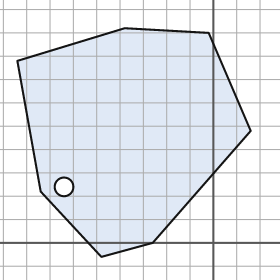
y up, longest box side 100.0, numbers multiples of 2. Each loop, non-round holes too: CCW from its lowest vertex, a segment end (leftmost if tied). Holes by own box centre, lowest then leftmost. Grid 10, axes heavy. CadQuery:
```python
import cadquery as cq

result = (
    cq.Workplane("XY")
    .moveTo(-48.0, -6.0)
    .lineTo(-26.0, 0.0)
    .lineTo(16.0, 48.0)
    .lineTo(-2.0, 90.0)
    .lineTo(-38.0, 92.0)
    .lineTo(-84.0, 78.0)
    .lineTo(-74.0, 22.0)
    .close()
    .moveTo(-64.0, 24.0)
    .circle(4.0)
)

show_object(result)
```